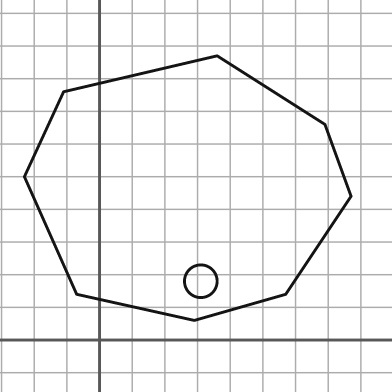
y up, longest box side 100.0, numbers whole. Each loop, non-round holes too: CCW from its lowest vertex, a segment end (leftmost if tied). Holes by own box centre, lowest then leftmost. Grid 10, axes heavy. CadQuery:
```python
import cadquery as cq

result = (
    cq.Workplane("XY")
    .moveTo(29.0, 6.0)
    .lineTo(57.0, 14.0)
    .lineTo(77.0, 44.0)
    .lineTo(69.0, 66.0)
    .lineTo(36.0, 87.0)
    .lineTo(-11.0, 76.0)
    .lineTo(-23.0, 50.0)
    .lineTo(-7.0, 14.0)
    .close()
    .moveTo(31.0, 18.0)
    .circle(5.0)
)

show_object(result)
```